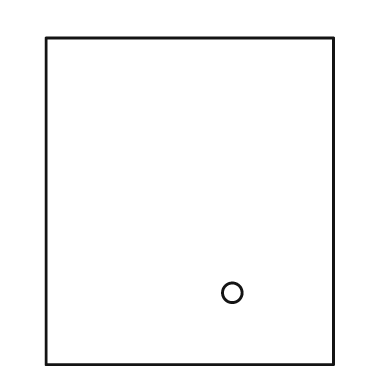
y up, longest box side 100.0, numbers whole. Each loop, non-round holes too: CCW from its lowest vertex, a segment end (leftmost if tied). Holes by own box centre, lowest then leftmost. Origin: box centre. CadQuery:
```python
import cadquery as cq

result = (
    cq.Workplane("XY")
    .moveTo(-44.0, -50.0)
    .lineTo(44.0, -50.0)
    .lineTo(44.0, 50.0)
    .lineTo(-44.0, 50.0)
    .close()
    .moveTo(13.0, -28.0)
    .circle(3.0)
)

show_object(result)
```